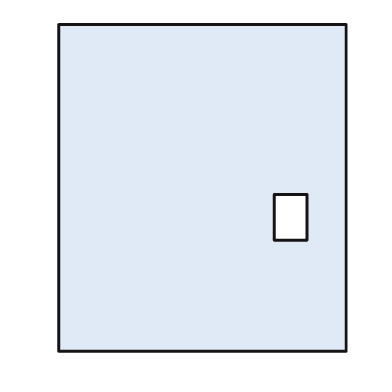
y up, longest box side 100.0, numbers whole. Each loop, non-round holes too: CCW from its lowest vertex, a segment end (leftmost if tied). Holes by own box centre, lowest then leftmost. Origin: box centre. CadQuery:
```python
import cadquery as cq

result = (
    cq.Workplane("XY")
    .moveTo(-44.0, -50.0)
    .lineTo(44.0, -50.0)
    .lineTo(44.0, 50.0)
    .lineTo(-44.0, 50.0)
    .close()
    .moveTo(22.0, -16.0)
    .lineTo(32.0, -16.0)
    .lineTo(32.0, -2.0)
    .lineTo(22.0, -2.0)
    .close()
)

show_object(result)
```